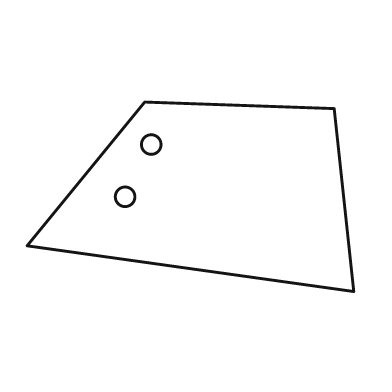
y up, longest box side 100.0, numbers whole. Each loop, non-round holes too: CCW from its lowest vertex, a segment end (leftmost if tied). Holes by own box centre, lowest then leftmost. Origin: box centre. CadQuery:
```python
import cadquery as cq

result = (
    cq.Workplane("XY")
    .moveTo(50.0, -29.0)
    .lineTo(44.0, 27.0)
    .lineTo(-14.0, 29.0)
    .lineTo(-50.0, -15.0)
    .close()
    .moveTo(-20.0, 0.0)
    .circle(3.0)
    .moveTo(-12.0, 16.0)
    .circle(3.0)
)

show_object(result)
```